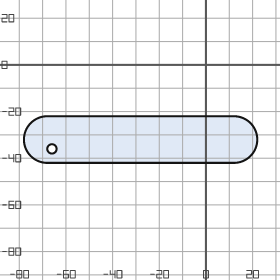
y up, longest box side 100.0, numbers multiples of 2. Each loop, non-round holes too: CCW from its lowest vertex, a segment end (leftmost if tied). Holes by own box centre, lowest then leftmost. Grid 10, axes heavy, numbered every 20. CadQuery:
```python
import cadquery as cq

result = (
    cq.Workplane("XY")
    .moveTo(-68.0, -42.0)
    .lineTo(12.0, -42.0)
    .threePointArc((22.0, -32.0), (12.0, -22.0))
    .lineTo(-68.0, -22.0)
    .threePointArc((-78.0, -32.0), (-68.0, -42.0))
    .close()
    .moveTo(-66.0, -36.0)
    .circle(2.0)
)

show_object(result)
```